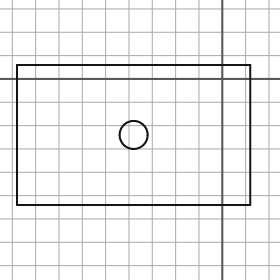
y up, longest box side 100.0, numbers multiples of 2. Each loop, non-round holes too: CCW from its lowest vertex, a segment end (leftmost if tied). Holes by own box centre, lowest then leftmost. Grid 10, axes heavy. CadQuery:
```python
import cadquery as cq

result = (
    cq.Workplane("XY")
    .moveTo(-88.0, -54.0)
    .lineTo(12.0, -54.0)
    .lineTo(12.0, 6.0)
    .lineTo(-88.0, 6.0)
    .close()
    .moveTo(-38.0, -24.0)
    .circle(6.0)
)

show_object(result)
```